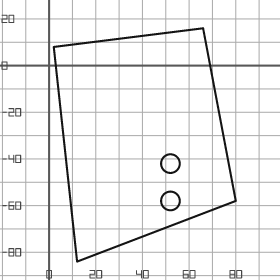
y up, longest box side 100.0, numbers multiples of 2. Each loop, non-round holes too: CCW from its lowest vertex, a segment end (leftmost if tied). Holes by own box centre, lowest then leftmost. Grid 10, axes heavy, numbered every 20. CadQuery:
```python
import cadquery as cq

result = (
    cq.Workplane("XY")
    .moveTo(12.0, -84.0)
    .lineTo(80.0, -58.0)
    .lineTo(66.0, 16.0)
    .lineTo(2.0, 8.0)
    .close()
    .moveTo(52.0, -58.0)
    .circle(4.0)
    .moveTo(52.0, -42.0)
    .circle(4.0)
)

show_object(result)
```